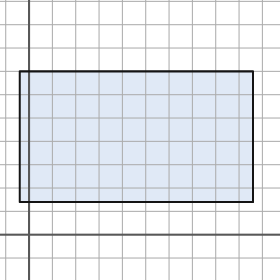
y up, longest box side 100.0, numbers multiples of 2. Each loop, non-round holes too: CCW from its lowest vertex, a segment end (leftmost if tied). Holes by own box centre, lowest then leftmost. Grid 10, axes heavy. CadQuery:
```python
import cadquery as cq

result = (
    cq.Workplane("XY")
    .moveTo(-4.0, 14.0)
    .lineTo(96.0, 14.0)
    .lineTo(96.0, 70.0)
    .lineTo(-4.0, 70.0)
    .close()
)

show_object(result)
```